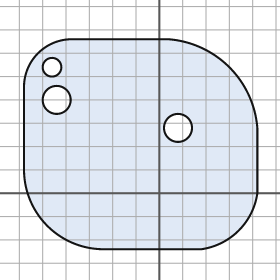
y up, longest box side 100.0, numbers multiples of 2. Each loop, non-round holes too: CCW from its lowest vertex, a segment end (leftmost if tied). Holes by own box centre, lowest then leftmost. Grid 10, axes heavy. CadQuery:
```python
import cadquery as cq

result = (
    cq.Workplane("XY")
    .moveTo(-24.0, -24.0)
    .lineTo(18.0, -24.0)
    .threePointArc((34.0, -16.0), (42.0, 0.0))
    .lineTo(42.0, 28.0)
    .threePointArc((30.0, 54.0), (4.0, 66.0))
    .lineTo(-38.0, 66.0)
    .threePointArc((-52.0, 60.0), (-58.0, 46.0))
    .lineTo(-58.0, 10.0)
    .threePointArc((-48.0, -14.0), (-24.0, -24.0))
    .close()
    .moveTo(8.0, 28.0)
    .circle(6.0)
    .moveTo(-44.0, 40.0)
    .circle(6.0)
    .moveTo(-46.0, 54.0)
    .circle(4.0)
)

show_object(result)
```